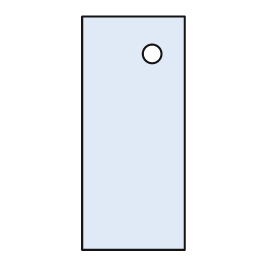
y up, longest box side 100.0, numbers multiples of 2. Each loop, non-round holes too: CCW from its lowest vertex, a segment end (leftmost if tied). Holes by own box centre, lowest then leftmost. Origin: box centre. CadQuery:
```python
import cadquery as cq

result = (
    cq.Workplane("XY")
    .moveTo(-22.0, -50.0)
    .lineTo(22.0, -50.0)
    .lineTo(22.0, 50.0)
    .lineTo(-22.0, 50.0)
    .close()
    .moveTo(8.0, 34.0)
    .circle(4.0)
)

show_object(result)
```